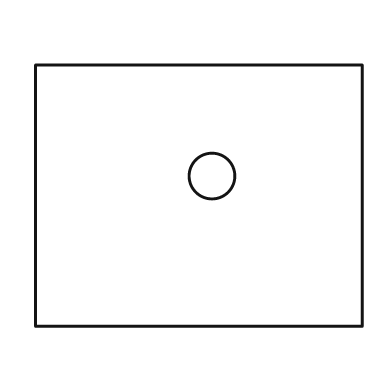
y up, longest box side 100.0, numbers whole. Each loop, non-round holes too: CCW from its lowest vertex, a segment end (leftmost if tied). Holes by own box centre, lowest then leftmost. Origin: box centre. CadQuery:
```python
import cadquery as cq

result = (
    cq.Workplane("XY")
    .moveTo(-50.0, -40.0)
    .lineTo(50.0, -40.0)
    .lineTo(50.0, 40.0)
    .lineTo(-50.0, 40.0)
    .close()
    .moveTo(4.0, 6.0)
    .circle(7.0)
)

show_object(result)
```